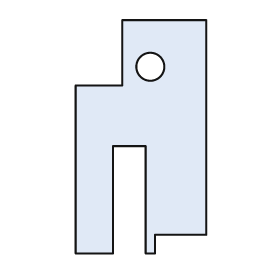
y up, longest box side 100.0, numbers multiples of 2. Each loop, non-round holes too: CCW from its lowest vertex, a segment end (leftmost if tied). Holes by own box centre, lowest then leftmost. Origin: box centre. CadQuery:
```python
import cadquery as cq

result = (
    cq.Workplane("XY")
    .moveTo(-28.0, -50.0)
    .lineTo(-12.0, -50.0)
    .lineTo(-12.0, -4.0)
    .lineTo(2.0, -4.0)
    .lineTo(2.0, -50.0)
    .lineTo(6.0, -50.0)
    .lineTo(6.0, -42.0)
    .lineTo(28.0, -42.0)
    .lineTo(28.0, 50.0)
    .lineTo(-8.0, 50.0)
    .lineTo(-8.0, 22.0)
    .lineTo(-28.0, 22.0)
    .close()
    .moveTo(4.0, 30.0)
    .circle(6.0)
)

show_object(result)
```